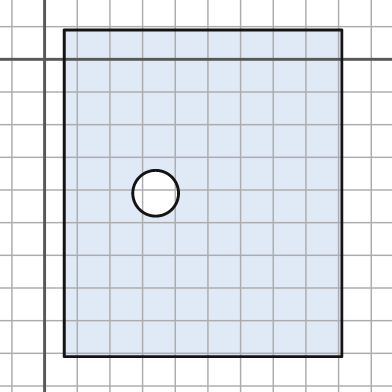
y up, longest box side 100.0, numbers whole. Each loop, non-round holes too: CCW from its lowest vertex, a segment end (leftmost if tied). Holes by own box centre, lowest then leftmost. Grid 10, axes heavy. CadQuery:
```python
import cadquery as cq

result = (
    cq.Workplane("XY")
    .moveTo(6.0, -91.0)
    .lineTo(91.0, -91.0)
    .lineTo(91.0, 9.0)
    .lineTo(6.0, 9.0)
    .close()
    .moveTo(34.0, -41.0)
    .circle(7.0)
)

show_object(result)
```